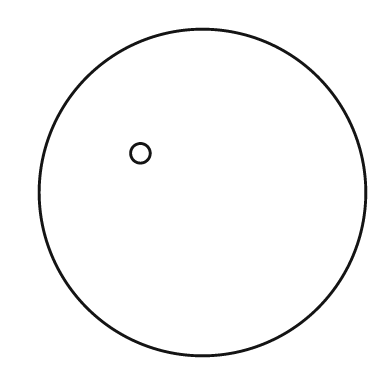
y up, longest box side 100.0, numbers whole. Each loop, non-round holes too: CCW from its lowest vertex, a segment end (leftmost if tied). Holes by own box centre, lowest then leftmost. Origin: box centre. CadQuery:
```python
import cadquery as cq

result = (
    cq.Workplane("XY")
    .moveTo(0.0, 0.0)
    .circle(50.0)
    .moveTo(-19.0, 12.0)
    .circle(3.0)
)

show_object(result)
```